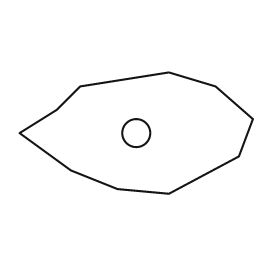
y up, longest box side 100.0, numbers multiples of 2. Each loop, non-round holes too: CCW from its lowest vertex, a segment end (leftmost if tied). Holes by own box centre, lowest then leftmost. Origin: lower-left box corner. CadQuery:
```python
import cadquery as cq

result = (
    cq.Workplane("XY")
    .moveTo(64.0, 0.0)
    .lineTo(94.0, 16.0)
    .lineTo(100.0, 32.0)
    .lineTo(84.0, 46.0)
    .lineTo(64.0, 52.0)
    .lineTo(26.0, 46.0)
    .lineTo(16.0, 36.0)
    .lineTo(0.0, 26.0)
    .lineTo(22.0, 10.0)
    .lineTo(42.0, 2.0)
    .close()
    .moveTo(50.0, 26.0)
    .circle(6.0)
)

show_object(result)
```